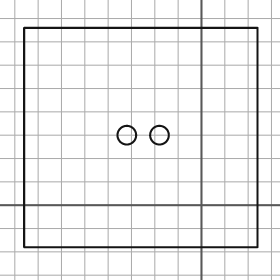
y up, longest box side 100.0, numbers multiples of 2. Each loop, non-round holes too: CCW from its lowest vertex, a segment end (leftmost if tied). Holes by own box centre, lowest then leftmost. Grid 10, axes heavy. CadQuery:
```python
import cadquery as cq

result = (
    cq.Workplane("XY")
    .moveTo(-76.0, -18.0)
    .lineTo(24.0, -18.0)
    .lineTo(24.0, 76.0)
    .lineTo(-76.0, 76.0)
    .close()
    .moveTo(-32.0, 30.0)
    .circle(4.0)
    .moveTo(-18.0, 30.0)
    .circle(4.0)
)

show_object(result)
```